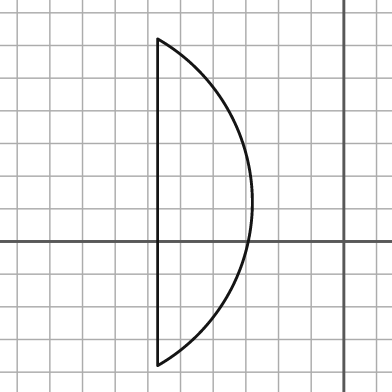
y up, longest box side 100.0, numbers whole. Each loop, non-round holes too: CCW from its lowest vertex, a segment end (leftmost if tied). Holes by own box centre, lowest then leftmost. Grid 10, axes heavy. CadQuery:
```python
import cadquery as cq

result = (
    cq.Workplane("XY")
    .moveTo(-57.0, -38.0)
    .threePointArc((-28.0, 12.0), (-57.0, 62.0))
    .close()
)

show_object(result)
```